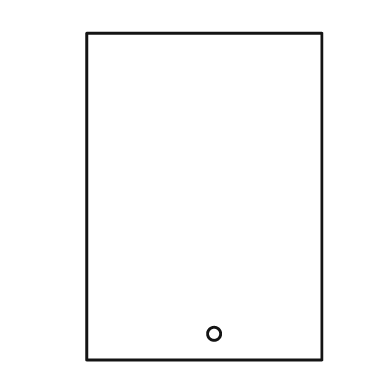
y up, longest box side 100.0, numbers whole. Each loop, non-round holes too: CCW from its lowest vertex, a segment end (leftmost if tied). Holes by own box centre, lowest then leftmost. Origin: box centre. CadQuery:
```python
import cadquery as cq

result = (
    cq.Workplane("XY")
    .moveTo(-36.0, -50.0)
    .lineTo(36.0, -50.0)
    .lineTo(36.0, 50.0)
    .lineTo(-36.0, 50.0)
    .close()
    .moveTo(3.0, -42.0)
    .circle(2.0)
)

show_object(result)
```